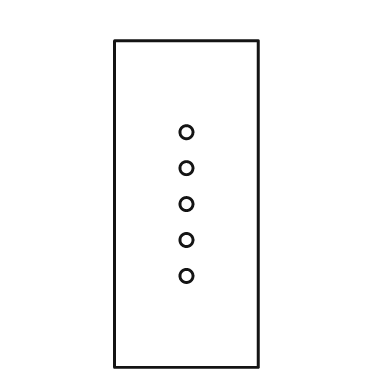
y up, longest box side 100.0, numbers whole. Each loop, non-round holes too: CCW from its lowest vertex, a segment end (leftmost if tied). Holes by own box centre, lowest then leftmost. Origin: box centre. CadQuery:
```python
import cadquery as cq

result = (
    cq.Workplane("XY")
    .moveTo(-22.0, -50.0)
    .lineTo(22.0, -50.0)
    .lineTo(22.0, 50.0)
    .lineTo(-22.0, 50.0)
    .close()
    .moveTo(0.0, -22.0)
    .circle(2.0)
    .moveTo(0.0, -11.0)
    .circle(2.0)
    .moveTo(0.0, 0.0)
    .circle(2.0)
    .moveTo(0.0, 11.0)
    .circle(2.0)
    .moveTo(0.0, 22.0)
    .circle(2.0)
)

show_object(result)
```